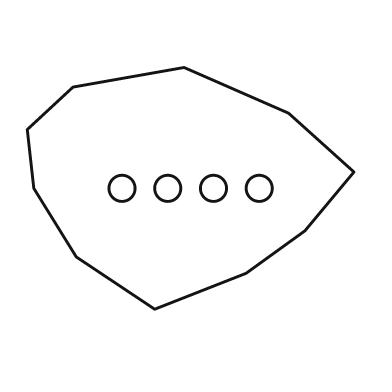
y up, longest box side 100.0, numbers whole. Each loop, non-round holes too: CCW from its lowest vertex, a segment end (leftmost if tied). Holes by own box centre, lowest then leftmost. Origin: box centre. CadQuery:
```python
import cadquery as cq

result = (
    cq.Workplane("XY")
    .moveTo(-11.0, -37.0)
    .lineTo(17.0, -26.0)
    .lineTo(35.0, -13.0)
    .lineTo(50.0, 5.0)
    .lineTo(30.0, 23.0)
    .lineTo(-2.0, 37.0)
    .lineTo(-36.0, 31.0)
    .lineTo(-50.0, 18.0)
    .lineTo(-48.0, 0.0)
    .lineTo(-35.0, -21.0)
    .close()
    .moveTo(-21.0, 0.0)
    .circle(4.0)
    .moveTo(-7.0, 0.0)
    .circle(4.0)
    .moveTo(7.0, 0.0)
    .circle(4.0)
    .moveTo(21.0, 0.0)
    .circle(4.0)
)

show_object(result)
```